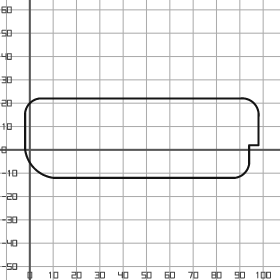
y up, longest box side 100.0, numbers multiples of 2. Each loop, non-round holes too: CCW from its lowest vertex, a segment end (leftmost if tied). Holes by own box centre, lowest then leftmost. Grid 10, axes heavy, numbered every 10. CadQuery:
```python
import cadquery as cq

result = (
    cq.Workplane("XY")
    .moveTo(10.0, -12.0)
    .lineTo(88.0, -12.0)
    .threePointArc((92.0, -10.0), (94.0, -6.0))
    .lineTo(94.0, 2.0)
    .lineTo(98.0, 2.0)
    .lineTo(98.0, 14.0)
    .threePointArc((96.0, 20.0), (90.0, 22.0))
    .lineTo(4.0, 22.0)
    .threePointArc((0.0, 20.0), (-2.0, 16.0))
    .lineTo(-2.0, 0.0)
    .threePointArc((2.0, -8.0), (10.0, -12.0))
    .close()
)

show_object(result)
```